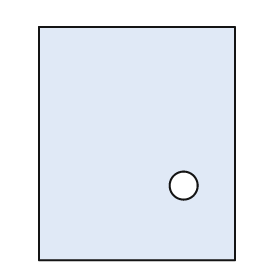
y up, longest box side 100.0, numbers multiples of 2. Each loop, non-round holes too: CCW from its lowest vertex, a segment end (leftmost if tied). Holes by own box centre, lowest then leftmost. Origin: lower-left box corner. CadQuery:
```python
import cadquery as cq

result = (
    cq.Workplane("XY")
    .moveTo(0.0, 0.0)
    .lineTo(84.0, 0.0)
    .lineTo(84.0, 100.0)
    .lineTo(0.0, 100.0)
    .close()
    .moveTo(62.0, 32.0)
    .circle(6.0)
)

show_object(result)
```